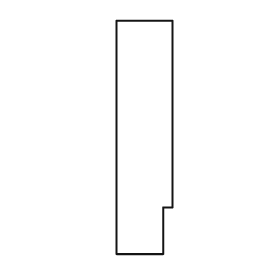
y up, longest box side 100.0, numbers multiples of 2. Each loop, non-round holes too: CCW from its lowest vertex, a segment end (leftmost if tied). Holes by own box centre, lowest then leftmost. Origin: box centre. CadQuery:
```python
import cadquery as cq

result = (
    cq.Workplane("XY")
    .moveTo(-12.0, -50.0)
    .lineTo(8.0, -50.0)
    .lineTo(8.0, -30.0)
    .lineTo(12.0, -30.0)
    .lineTo(12.0, 50.0)
    .lineTo(-12.0, 50.0)
    .close()
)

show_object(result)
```